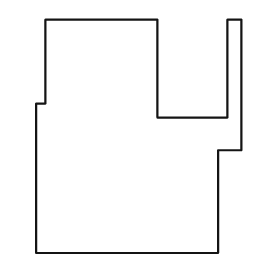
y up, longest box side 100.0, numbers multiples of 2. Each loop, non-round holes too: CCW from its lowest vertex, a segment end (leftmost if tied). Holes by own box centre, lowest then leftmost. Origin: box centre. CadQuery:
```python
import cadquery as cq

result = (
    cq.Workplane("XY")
    .moveTo(-44.0, -50.0)
    .lineTo(34.0, -50.0)
    .lineTo(34.0, -6.0)
    .lineTo(44.0, -6.0)
    .lineTo(44.0, 50.0)
    .lineTo(38.0, 50.0)
    .lineTo(38.0, 8.0)
    .lineTo(8.0, 8.0)
    .lineTo(8.0, 50.0)
    .lineTo(-40.0, 50.0)
    .lineTo(-40.0, 14.0)
    .lineTo(-44.0, 14.0)
    .close()
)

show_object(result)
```